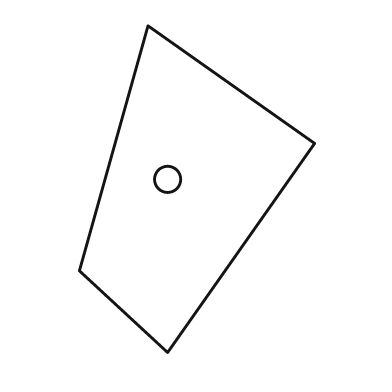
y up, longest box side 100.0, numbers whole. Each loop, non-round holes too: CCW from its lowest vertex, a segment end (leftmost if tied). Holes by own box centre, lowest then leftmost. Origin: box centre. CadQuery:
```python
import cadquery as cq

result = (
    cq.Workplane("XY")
    .moveTo(-9.0, -50.0)
    .lineTo(36.0, 14.0)
    .lineTo(-15.0, 50.0)
    .lineTo(-36.0, -25.0)
    .close()
    .moveTo(-9.0, 3.0)
    .circle(4.0)
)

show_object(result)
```